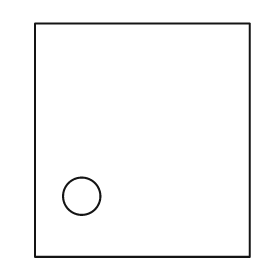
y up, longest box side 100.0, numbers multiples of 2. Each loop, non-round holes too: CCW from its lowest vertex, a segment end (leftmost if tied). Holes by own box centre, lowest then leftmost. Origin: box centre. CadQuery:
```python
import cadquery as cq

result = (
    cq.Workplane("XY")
    .moveTo(-46.0, -50.0)
    .lineTo(46.0, -50.0)
    .lineTo(46.0, 50.0)
    .lineTo(-46.0, 50.0)
    .close()
    .moveTo(-26.0, -24.0)
    .circle(8.0)
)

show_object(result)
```